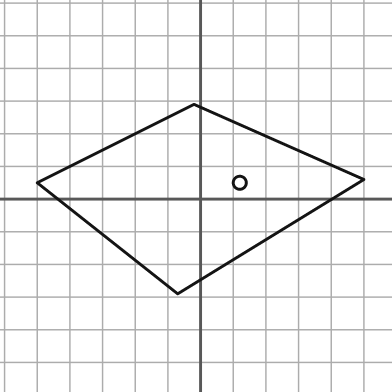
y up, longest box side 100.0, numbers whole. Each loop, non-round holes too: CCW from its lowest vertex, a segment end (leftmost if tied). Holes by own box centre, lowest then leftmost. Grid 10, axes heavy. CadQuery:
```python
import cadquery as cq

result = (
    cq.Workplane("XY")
    .moveTo(-7.0, -29.0)
    .lineTo(50.0, 6.0)
    .lineTo(-2.0, 29.0)
    .lineTo(-50.0, 5.0)
    .close()
    .moveTo(12.0, 5.0)
    .circle(2.0)
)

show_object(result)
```